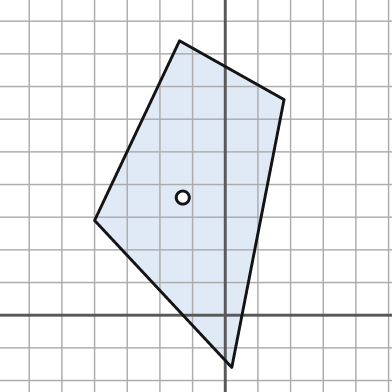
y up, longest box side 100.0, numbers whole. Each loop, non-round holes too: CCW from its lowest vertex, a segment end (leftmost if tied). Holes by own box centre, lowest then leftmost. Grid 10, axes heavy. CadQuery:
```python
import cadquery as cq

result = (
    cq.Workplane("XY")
    .moveTo(2.0, -16.0)
    .lineTo(18.0, 66.0)
    .lineTo(-14.0, 84.0)
    .lineTo(-40.0, 29.0)
    .close()
    .moveTo(-13.0, 36.0)
    .circle(2.0)
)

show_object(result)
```